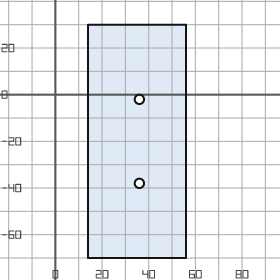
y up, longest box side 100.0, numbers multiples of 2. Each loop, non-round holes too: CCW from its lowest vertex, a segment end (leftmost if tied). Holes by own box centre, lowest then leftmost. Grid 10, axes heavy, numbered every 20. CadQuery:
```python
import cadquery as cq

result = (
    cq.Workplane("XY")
    .moveTo(14.0, -70.0)
    .lineTo(56.0, -70.0)
    .lineTo(56.0, 30.0)
    .lineTo(14.0, 30.0)
    .close()
    .moveTo(36.0, -38.0)
    .circle(2.0)
    .moveTo(36.0, -2.0)
    .circle(2.0)
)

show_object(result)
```